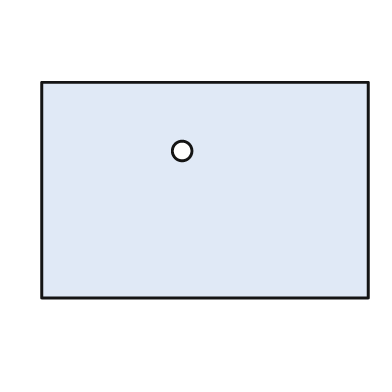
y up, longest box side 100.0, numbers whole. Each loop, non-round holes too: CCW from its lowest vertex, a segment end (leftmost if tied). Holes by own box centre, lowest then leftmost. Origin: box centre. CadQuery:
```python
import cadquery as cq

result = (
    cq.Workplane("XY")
    .moveTo(-50.0, -33.0)
    .lineTo(50.0, -33.0)
    .lineTo(50.0, 33.0)
    .lineTo(-50.0, 33.0)
    .close()
    .moveTo(-7.0, 12.0)
    .circle(3.0)
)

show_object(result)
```